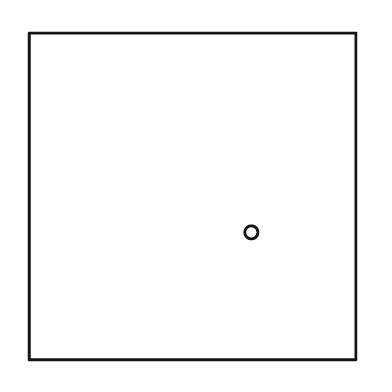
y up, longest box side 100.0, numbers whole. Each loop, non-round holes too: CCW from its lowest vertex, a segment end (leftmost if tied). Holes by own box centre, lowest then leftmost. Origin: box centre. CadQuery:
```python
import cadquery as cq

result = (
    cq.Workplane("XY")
    .moveTo(-50.0, -50.0)
    .lineTo(50.0, -50.0)
    .lineTo(50.0, 50.0)
    .lineTo(-50.0, 50.0)
    .close()
    .moveTo(18.0, -11.0)
    .circle(2.0)
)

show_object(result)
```